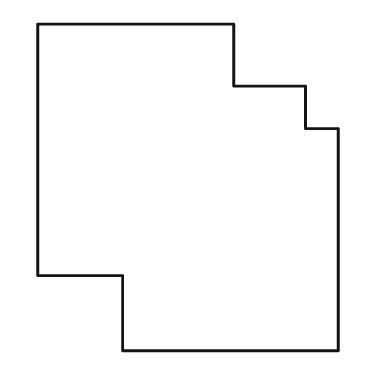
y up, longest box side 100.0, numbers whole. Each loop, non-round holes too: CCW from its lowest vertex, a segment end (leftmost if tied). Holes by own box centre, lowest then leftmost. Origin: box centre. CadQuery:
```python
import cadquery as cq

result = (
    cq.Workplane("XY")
    .moveTo(-20.0, -50.0)
    .lineTo(46.0, -50.0)
    .lineTo(46.0, 18.0)
    .lineTo(36.0, 18.0)
    .lineTo(36.0, 31.0)
    .lineTo(14.0, 31.0)
    .lineTo(14.0, 50.0)
    .lineTo(-46.0, 50.0)
    .lineTo(-46.0, -27.0)
    .lineTo(-20.0, -27.0)
    .close()
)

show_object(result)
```